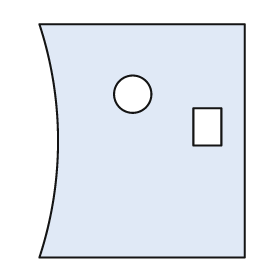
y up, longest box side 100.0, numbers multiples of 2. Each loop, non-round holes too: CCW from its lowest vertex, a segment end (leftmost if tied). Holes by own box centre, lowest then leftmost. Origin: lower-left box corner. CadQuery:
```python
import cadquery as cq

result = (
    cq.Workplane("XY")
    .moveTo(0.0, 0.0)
    .lineTo(88.0, 0.0)
    .lineTo(88.0, 100.0)
    .lineTo(0.0, 100.0)
    .threePointArc((8.0, 50.0), (0.0, 0.0))
    .close()
    .moveTo(66.0, 48.0)
    .lineTo(78.0, 48.0)
    .lineTo(78.0, 64.0)
    .lineTo(66.0, 64.0)
    .close()
    .moveTo(40.0, 70.0)
    .circle(8.0)
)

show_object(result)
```